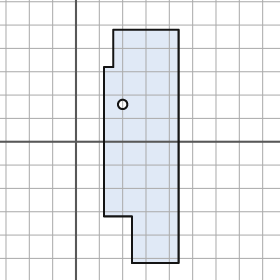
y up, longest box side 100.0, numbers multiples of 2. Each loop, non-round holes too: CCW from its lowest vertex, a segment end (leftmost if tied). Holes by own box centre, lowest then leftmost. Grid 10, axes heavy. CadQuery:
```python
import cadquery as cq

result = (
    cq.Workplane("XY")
    .moveTo(24.0, -52.0)
    .lineTo(44.0, -52.0)
    .lineTo(44.0, 48.0)
    .lineTo(16.0, 48.0)
    .lineTo(16.0, 32.0)
    .lineTo(12.0, 32.0)
    .lineTo(12.0, -32.0)
    .lineTo(24.0, -32.0)
    .close()
    .moveTo(20.0, 16.0)
    .circle(2.0)
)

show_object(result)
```